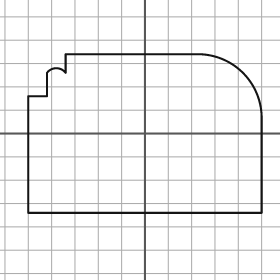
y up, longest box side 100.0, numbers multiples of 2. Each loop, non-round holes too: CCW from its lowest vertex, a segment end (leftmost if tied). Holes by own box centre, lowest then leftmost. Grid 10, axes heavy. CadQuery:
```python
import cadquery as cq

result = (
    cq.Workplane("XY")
    .moveTo(-50.0, -34.0)
    .lineTo(50.0, -34.0)
    .lineTo(50.0, 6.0)
    .threePointArc((42.0, 26.0), (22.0, 34.0))
    .lineTo(-34.0, 34.0)
    .lineTo(-34.0, 26.0)
    .threePointArc((-38.0, 28.0), (-42.0, 26.0))
    .lineTo(-42.0, 16.0)
    .lineTo(-50.0, 16.0)
    .close()
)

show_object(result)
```